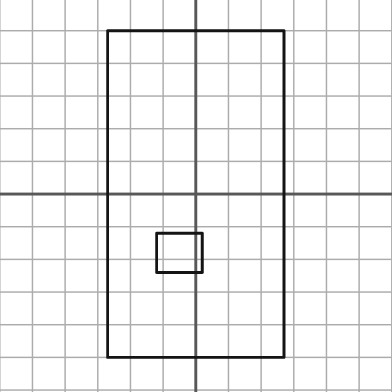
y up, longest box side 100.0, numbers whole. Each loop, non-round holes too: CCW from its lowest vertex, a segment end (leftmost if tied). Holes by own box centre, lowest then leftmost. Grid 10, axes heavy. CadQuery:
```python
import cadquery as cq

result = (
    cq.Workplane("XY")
    .moveTo(-27.0, -50.0)
    .lineTo(27.0, -50.0)
    .lineTo(27.0, 50.0)
    .lineTo(-27.0, 50.0)
    .close()
    .moveTo(-12.0, -24.0)
    .lineTo(2.0, -24.0)
    .lineTo(2.0, -12.0)
    .lineTo(-12.0, -12.0)
    .close()
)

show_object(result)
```